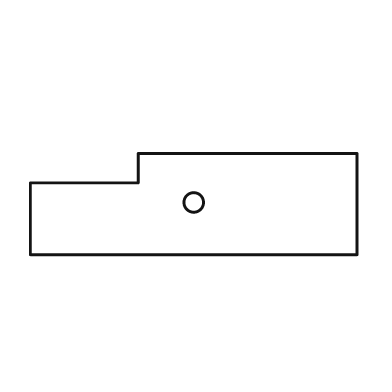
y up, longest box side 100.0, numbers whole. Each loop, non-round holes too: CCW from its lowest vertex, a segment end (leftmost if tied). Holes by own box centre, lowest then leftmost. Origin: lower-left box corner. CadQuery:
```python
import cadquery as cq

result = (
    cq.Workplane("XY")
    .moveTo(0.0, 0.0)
    .lineTo(100.0, 0.0)
    .lineTo(100.0, 31.0)
    .lineTo(33.0, 31.0)
    .lineTo(33.0, 22.0)
    .lineTo(0.0, 22.0)
    .close()
    .moveTo(50.0, 16.0)
    .circle(3.0)
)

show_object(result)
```